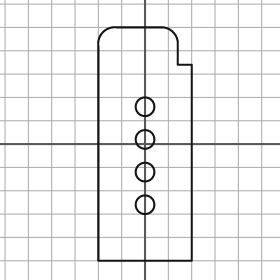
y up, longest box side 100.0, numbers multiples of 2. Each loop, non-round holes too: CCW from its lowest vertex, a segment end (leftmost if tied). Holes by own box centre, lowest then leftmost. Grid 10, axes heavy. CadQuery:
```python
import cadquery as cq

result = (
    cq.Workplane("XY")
    .moveTo(-20.0, -50.0)
    .lineTo(20.0, -50.0)
    .lineTo(20.0, 34.0)
    .lineTo(14.0, 34.0)
    .lineTo(14.0, 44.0)
    .threePointArc((12.0, 48.0), (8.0, 50.0))
    .lineTo(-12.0, 50.0)
    .threePointArc((-18.0, 48.0), (-20.0, 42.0))
    .close()
    .moveTo(0.0, -26.0)
    .circle(4.0)
    .moveTo(0.0, -12.0)
    .circle(4.0)
    .moveTo(0.0, 2.0)
    .circle(4.0)
    .moveTo(0.0, 16.0)
    .circle(4.0)
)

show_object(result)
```